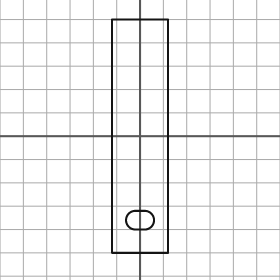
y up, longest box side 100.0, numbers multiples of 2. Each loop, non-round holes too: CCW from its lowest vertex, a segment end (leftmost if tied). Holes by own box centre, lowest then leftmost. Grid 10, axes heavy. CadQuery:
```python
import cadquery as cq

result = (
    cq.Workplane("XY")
    .moveTo(-12.0, -50.0)
    .lineTo(12.0, -50.0)
    .lineTo(12.0, 50.0)
    .lineTo(-12.0, 50.0)
    .close()
    .moveTo(-2.0, -40.0)
    .lineTo(2.0, -40.0)
    .threePointArc((6.0, -36.0), (2.0, -32.0))
    .lineTo(-2.0, -32.0)
    .threePointArc((-6.0, -36.0), (-2.0, -40.0))
    .close()
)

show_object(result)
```